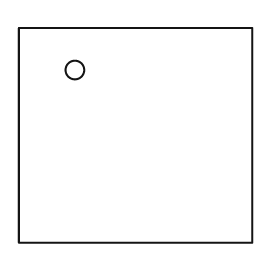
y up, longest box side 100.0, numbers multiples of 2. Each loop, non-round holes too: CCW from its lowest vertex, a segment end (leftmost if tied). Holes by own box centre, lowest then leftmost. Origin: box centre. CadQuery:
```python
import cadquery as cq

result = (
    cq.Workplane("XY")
    .moveTo(-50.0, -46.0)
    .lineTo(50.0, -46.0)
    .lineTo(50.0, 46.0)
    .lineTo(-50.0, 46.0)
    .close()
    .moveTo(-26.0, 28.0)
    .circle(4.0)
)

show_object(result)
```